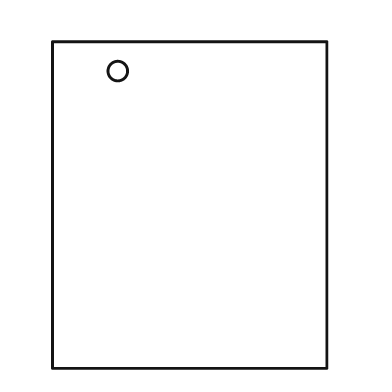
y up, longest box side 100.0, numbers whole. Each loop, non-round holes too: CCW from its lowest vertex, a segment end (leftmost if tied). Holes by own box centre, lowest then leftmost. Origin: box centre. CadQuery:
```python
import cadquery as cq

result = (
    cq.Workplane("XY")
    .moveTo(-42.0, -50.0)
    .lineTo(42.0, -50.0)
    .lineTo(42.0, 50.0)
    .lineTo(-42.0, 50.0)
    .close()
    .moveTo(-22.0, 41.0)
    .circle(3.0)
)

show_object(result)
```